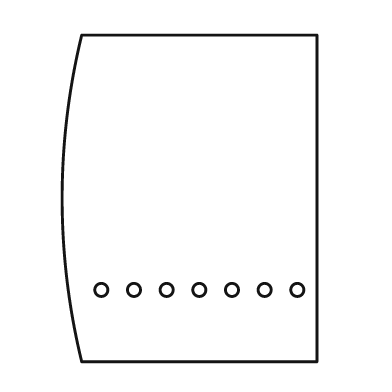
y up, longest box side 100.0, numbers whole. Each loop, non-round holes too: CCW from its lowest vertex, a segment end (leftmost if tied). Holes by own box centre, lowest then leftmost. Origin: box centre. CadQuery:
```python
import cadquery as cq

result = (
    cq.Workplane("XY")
    .moveTo(-33.0, -50.0)
    .lineTo(39.0, -50.0)
    .lineTo(39.0, 50.0)
    .lineTo(-33.0, 50.0)
    .threePointArc((-39.0, 0.0), (-33.0, -50.0))
    .close()
    .moveTo(-27.0, -28.0)
    .circle(2.0)
    .moveTo(-17.0, -28.0)
    .circle(2.0)
    .moveTo(-7.0, -28.0)
    .circle(2.0)
    .moveTo(3.0, -28.0)
    .circle(2.0)
    .moveTo(13.0, -28.0)
    .circle(2.0)
    .moveTo(23.0, -28.0)
    .circle(2.0)
    .moveTo(33.0, -28.0)
    .circle(2.0)
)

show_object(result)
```